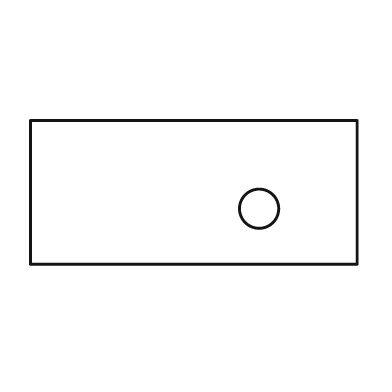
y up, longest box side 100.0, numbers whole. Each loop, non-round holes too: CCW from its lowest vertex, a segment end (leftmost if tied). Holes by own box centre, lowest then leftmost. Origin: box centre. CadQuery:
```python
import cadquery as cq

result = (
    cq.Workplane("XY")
    .moveTo(-50.0, -22.0)
    .lineTo(50.0, -22.0)
    .lineTo(50.0, 22.0)
    .lineTo(-50.0, 22.0)
    .close()
    .moveTo(20.0, -5.0)
    .circle(6.0)
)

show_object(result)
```